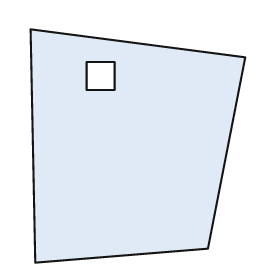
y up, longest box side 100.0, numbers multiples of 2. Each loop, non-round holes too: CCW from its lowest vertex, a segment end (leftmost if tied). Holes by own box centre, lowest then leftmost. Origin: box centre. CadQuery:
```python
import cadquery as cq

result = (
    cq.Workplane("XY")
    .moveTo(-44.0, -50.0)
    .lineTo(30.0, -44.0)
    .lineTo(46.0, 38.0)
    .lineTo(-46.0, 50.0)
    .close()
    .moveTo(-22.0, 24.0)
    .lineTo(-10.0, 24.0)
    .lineTo(-10.0, 36.0)
    .lineTo(-22.0, 36.0)
    .close()
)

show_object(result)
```